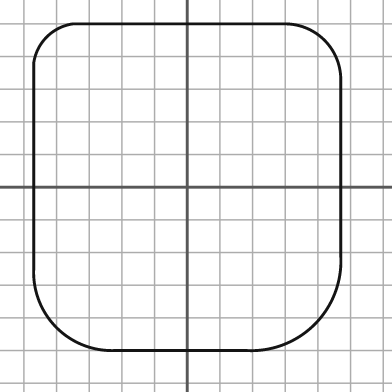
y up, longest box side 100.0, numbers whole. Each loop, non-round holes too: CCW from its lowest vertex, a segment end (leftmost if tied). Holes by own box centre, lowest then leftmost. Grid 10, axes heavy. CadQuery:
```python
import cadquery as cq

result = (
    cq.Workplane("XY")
    .moveTo(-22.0, -50.0)
    .lineTo(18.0, -50.0)
    .threePointArc((39.0, -42.0), (47.0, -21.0))
    .lineTo(47.0, 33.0)
    .threePointArc((42.0, 45.0), (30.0, 50.0))
    .lineTo(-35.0, 50.0)
    .threePointArc((-43.0, 46.0), (-47.0, 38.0))
    .lineTo(-47.0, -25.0)
    .threePointArc((-40.0, -43.0), (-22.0, -50.0))
    .close()
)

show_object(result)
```